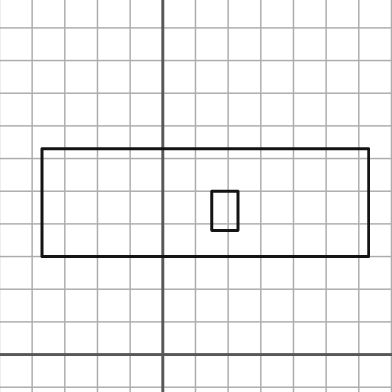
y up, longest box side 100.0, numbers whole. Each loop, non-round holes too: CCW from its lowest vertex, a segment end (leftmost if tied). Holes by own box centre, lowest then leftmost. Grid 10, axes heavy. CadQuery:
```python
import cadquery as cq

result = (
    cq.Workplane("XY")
    .moveTo(-37.0, 30.0)
    .lineTo(63.0, 30.0)
    .lineTo(63.0, 63.0)
    .lineTo(-37.0, 63.0)
    .close()
    .moveTo(15.0, 38.0)
    .lineTo(23.0, 38.0)
    .lineTo(23.0, 50.0)
    .lineTo(15.0, 50.0)
    .close()
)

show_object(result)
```